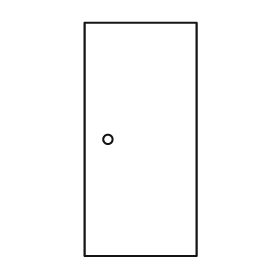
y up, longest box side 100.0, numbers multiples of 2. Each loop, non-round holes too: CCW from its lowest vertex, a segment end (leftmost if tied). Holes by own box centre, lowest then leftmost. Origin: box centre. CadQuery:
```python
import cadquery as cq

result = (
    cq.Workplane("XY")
    .moveTo(-24.0, -50.0)
    .lineTo(24.0, -50.0)
    .lineTo(24.0, 50.0)
    .lineTo(-24.0, 50.0)
    .close()
    .moveTo(-14.0, 0.0)
    .circle(2.0)
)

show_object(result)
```